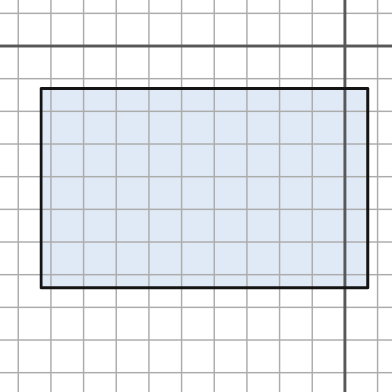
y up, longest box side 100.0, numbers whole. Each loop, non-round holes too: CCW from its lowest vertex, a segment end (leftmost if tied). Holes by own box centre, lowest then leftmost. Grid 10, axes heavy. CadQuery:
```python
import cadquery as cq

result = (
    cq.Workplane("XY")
    .moveTo(-93.0, -74.0)
    .lineTo(7.0, -74.0)
    .lineTo(7.0, -13.0)
    .lineTo(-93.0, -13.0)
    .close()
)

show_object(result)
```